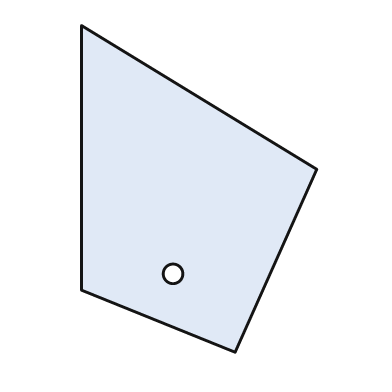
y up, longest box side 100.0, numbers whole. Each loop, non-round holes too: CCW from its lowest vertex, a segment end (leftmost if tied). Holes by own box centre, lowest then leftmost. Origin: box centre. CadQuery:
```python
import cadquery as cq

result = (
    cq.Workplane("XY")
    .moveTo(11.0, -50.0)
    .lineTo(36.0, 6.0)
    .lineTo(-36.0, 50.0)
    .lineTo(-36.0, -31.0)
    .close()
    .moveTo(-8.0, -26.0)
    .circle(3.0)
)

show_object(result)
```